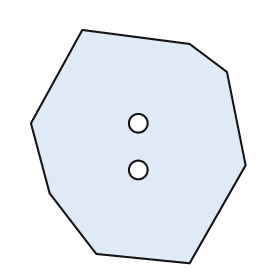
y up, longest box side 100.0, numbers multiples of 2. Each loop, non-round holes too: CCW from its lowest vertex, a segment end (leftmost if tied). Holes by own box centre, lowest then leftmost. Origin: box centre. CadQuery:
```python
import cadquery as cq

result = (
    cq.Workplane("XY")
    .moveTo(22.0, -50.0)
    .lineTo(46.0, -8.0)
    .lineTo(38.0, 32.0)
    .lineTo(22.0, 44.0)
    .lineTo(-24.0, 50.0)
    .lineTo(-46.0, 10.0)
    .lineTo(-38.0, -20.0)
    .lineTo(-18.0, -46.0)
    .close()
    .moveTo(0.0, -10.0)
    .circle(4.0)
    .moveTo(0.0, 10.0)
    .circle(4.0)
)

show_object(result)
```